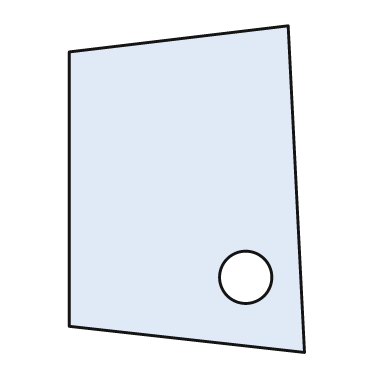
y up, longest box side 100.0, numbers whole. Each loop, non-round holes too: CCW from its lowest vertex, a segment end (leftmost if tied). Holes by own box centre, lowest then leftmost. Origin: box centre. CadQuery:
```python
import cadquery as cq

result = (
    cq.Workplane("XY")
    .moveTo(36.0, -50.0)
    .lineTo(31.0, 50.0)
    .lineTo(-36.0, 42.0)
    .lineTo(-36.0, -42.0)
    .close()
    .moveTo(18.0, -27.0)
    .circle(8.0)
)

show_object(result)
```